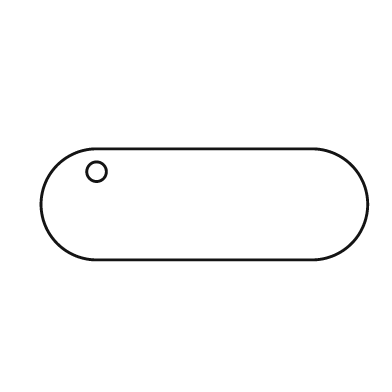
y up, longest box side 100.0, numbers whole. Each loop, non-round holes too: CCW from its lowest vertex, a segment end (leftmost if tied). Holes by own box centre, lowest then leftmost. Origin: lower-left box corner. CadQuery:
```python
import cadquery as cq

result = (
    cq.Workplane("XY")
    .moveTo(17.0, 0.0)
    .lineTo(83.0, 0.0)
    .threePointArc((100.0, 17.0), (83.0, 34.0))
    .lineTo(17.0, 34.0)
    .threePointArc((0.0, 17.0), (17.0, 0.0))
    .close()
    .moveTo(17.0, 27.0)
    .circle(3.0)
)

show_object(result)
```